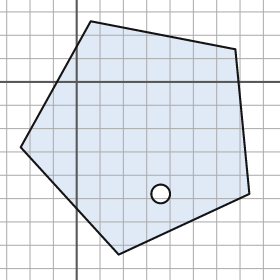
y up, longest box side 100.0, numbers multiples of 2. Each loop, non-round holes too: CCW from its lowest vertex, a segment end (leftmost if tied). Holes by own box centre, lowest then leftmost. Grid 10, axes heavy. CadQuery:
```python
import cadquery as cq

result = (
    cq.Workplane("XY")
    .moveTo(18.0, -74.0)
    .lineTo(74.0, -48.0)
    .lineTo(68.0, 14.0)
    .lineTo(6.0, 26.0)
    .lineTo(-24.0, -28.0)
    .close()
    .moveTo(36.0, -48.0)
    .circle(4.0)
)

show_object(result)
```